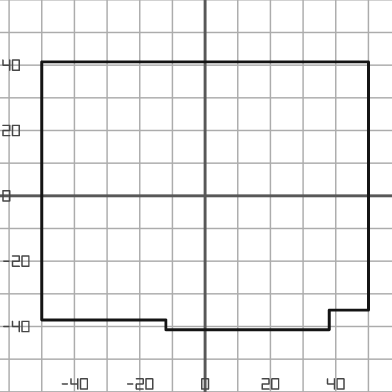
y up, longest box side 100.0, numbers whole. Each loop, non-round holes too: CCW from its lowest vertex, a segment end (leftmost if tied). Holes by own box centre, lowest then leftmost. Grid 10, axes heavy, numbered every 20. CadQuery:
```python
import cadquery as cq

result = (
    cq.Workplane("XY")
    .moveTo(-12.0, -41.0)
    .lineTo(38.0, -41.0)
    .lineTo(38.0, -35.0)
    .lineTo(50.0, -35.0)
    .lineTo(50.0, 41.0)
    .lineTo(-50.0, 41.0)
    .lineTo(-50.0, -38.0)
    .lineTo(-12.0, -38.0)
    .close()
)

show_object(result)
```